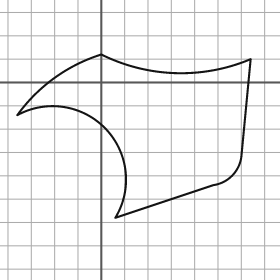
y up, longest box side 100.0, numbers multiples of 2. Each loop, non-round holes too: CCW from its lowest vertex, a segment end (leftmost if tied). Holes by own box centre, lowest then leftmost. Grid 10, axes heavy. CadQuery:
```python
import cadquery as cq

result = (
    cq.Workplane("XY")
    .moveTo(6.0, -58.0)
    .lineTo(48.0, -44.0)
    .threePointArc((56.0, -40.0), (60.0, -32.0))
    .lineTo(64.0, 10.0)
    .threePointArc((32.0, 4.0), (0.0, 12.0))
    .threePointArc((-20.0, 2.0), (-36.0, -14.0))
    .threePointArc((2.0, -20.0), (6.0, -58.0))
    .close()
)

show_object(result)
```